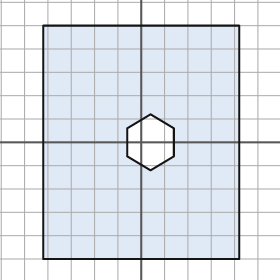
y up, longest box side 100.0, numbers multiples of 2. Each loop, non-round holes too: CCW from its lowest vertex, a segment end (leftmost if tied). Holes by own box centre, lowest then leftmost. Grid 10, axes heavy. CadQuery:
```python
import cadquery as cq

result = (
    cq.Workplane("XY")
    .moveTo(-42.0, -50.0)
    .lineTo(42.0, -50.0)
    .lineTo(42.0, 50.0)
    .lineTo(-42.0, 50.0)
    .close()
    .moveTo(4.0, -12.0)
    .lineTo(14.0, -6.0)
    .lineTo(14.0, 6.0)
    .lineTo(4.0, 12.0)
    .lineTo(-6.0, 6.0)
    .lineTo(-6.0, -6.0)
    .close()
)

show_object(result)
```